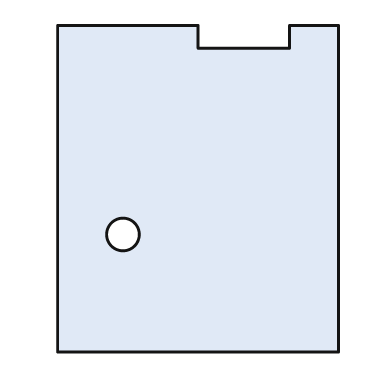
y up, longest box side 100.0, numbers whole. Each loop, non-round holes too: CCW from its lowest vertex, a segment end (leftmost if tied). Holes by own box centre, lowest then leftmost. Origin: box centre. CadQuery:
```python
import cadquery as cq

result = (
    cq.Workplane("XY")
    .moveTo(-43.0, -50.0)
    .lineTo(43.0, -50.0)
    .lineTo(43.0, 50.0)
    .lineTo(28.0, 50.0)
    .lineTo(28.0, 43.0)
    .lineTo(0.0, 43.0)
    .lineTo(0.0, 50.0)
    .lineTo(-43.0, 50.0)
    .close()
    .moveTo(-23.0, -14.0)
    .circle(5.0)
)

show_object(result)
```